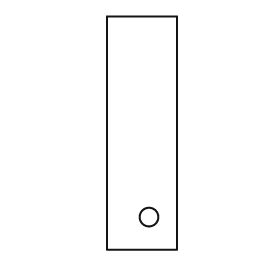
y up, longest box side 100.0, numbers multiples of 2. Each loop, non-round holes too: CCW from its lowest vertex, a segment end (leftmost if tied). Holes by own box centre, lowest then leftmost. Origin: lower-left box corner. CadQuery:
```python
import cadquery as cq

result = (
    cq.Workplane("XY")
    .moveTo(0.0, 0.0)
    .lineTo(30.0, 0.0)
    .lineTo(30.0, 100.0)
    .lineTo(0.0, 100.0)
    .close()
    .moveTo(18.0, 14.0)
    .circle(4.0)
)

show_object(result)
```